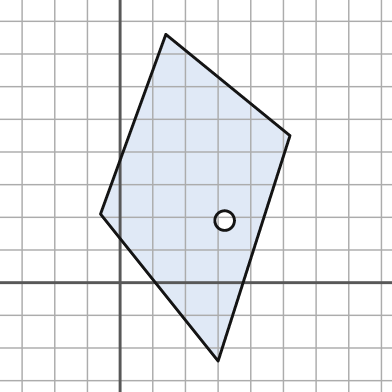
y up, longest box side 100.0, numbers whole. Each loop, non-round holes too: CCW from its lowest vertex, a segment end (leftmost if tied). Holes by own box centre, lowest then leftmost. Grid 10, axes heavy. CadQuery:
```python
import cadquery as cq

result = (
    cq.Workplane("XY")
    .moveTo(30.0, -24.0)
    .lineTo(52.0, 45.0)
    .lineTo(14.0, 76.0)
    .lineTo(-6.0, 21.0)
    .close()
    .moveTo(32.0, 19.0)
    .circle(3.0)
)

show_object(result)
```